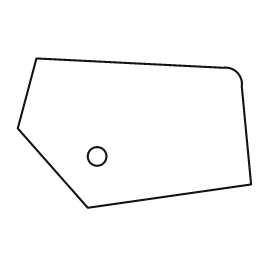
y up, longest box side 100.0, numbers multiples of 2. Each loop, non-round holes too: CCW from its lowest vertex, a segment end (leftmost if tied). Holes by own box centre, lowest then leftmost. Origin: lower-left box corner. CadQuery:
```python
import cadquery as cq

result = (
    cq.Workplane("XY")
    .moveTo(30.0, 0.0)
    .lineTo(100.0, 10.0)
    .lineTo(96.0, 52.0)
    .threePointArc((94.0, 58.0), (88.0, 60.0))
    .lineTo(8.0, 64.0)
    .lineTo(0.0, 34.0)
    .close()
    .moveTo(34.0, 22.0)
    .circle(4.0)
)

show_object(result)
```